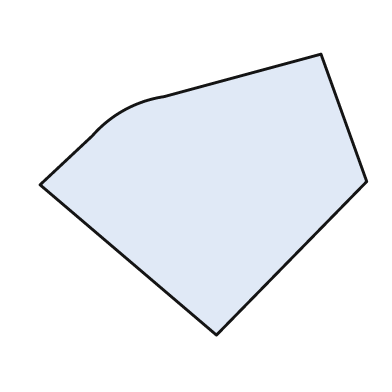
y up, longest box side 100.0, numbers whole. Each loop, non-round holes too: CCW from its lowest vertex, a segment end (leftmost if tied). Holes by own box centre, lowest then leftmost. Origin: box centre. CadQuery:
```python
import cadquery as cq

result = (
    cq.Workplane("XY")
    .moveTo(4.0, -43.0)
    .lineTo(50.0, 4.0)
    .lineTo(36.0, 43.0)
    .lineTo(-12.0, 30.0)
    .threePointArc((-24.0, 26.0), (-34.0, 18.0))
    .lineTo(-50.0, 3.0)
    .close()
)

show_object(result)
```